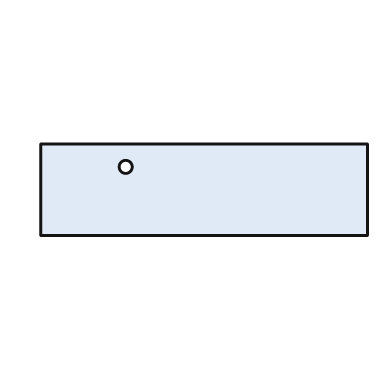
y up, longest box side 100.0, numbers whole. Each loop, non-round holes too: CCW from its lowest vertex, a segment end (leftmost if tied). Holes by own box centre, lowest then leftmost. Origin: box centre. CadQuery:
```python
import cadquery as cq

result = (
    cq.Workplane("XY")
    .moveTo(-50.0, -14.0)
    .lineTo(50.0, -14.0)
    .lineTo(50.0, 14.0)
    .lineTo(-50.0, 14.0)
    .close()
    .moveTo(-24.0, 7.0)
    .circle(2.0)
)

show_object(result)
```